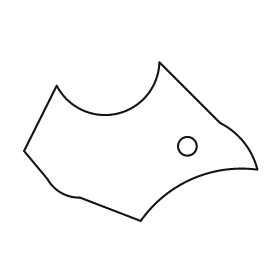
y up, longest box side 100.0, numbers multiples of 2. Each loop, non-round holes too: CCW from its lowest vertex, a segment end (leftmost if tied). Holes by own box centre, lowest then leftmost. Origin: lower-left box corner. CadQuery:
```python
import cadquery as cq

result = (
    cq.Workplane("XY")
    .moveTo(50.0, 0.0)
    .threePointArc((72.0, 18.0), (100.0, 22.0))
    .threePointArc((94.0, 34.0), (84.0, 42.0))
    .lineTo(58.0, 68.0)
    .threePointArc((40.0, 46.0), (14.0, 58.0))
    .lineTo(0.0, 30.0)
    .lineTo(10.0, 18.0)
    .threePointArc((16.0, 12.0), (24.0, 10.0))
    .close()
    .moveTo(70.0, 32.0)
    .circle(4.0)
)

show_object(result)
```